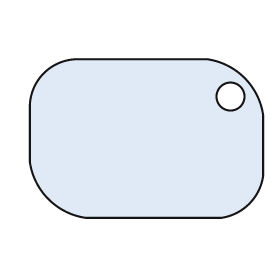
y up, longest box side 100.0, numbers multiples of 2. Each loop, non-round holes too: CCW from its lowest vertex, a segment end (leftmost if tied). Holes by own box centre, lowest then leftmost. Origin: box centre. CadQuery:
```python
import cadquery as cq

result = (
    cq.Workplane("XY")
    .moveTo(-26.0, -34.0)
    .lineTo(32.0, -34.0)
    .threePointArc((44.0, -28.0), (50.0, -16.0))
    .lineTo(50.0, 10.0)
    .threePointArc((42.0, 26.0), (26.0, 34.0))
    .lineTo(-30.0, 34.0)
    .threePointArc((-44.0, 28.0), (-50.0, 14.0))
    .lineTo(-50.0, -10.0)
    .threePointArc((-42.0, -26.0), (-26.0, -34.0))
    .close()
    .moveTo(36.0, 18.0)
    .circle(6.0)
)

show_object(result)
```